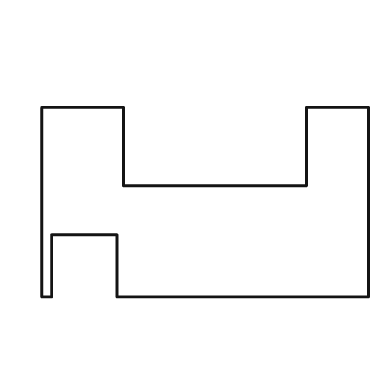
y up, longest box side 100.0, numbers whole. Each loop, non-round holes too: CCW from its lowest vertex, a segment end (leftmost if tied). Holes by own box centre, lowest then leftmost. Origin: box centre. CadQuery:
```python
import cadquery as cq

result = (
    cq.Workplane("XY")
    .moveTo(-50.0, -29.0)
    .lineTo(-47.0, -29.0)
    .lineTo(-47.0, -10.0)
    .lineTo(-27.0, -10.0)
    .lineTo(-27.0, -29.0)
    .lineTo(50.0, -29.0)
    .lineTo(50.0, 29.0)
    .lineTo(31.0, 29.0)
    .lineTo(31.0, 5.0)
    .lineTo(-25.0, 5.0)
    .lineTo(-25.0, 29.0)
    .lineTo(-50.0, 29.0)
    .close()
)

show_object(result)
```